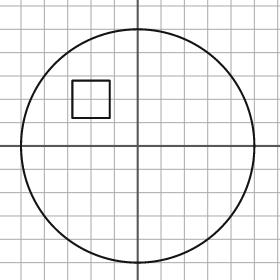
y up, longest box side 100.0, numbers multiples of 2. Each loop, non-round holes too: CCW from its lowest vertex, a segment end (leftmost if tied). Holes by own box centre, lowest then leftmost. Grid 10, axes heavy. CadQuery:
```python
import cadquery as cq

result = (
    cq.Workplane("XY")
    .moveTo(0.0, 0.0)
    .circle(50.0)
    .moveTo(-28.0, 12.0)
    .lineTo(-12.0, 12.0)
    .lineTo(-12.0, 28.0)
    .lineTo(-28.0, 28.0)
    .close()
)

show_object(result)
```